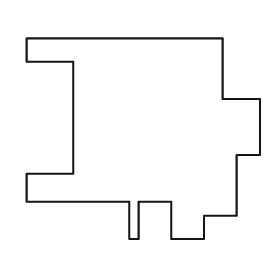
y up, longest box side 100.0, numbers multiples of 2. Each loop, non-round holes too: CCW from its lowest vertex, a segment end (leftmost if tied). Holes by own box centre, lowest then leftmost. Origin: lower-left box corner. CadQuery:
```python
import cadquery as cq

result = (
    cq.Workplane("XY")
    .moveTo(44.0, 0.0)
    .lineTo(48.0, 0.0)
    .lineTo(48.0, 16.0)
    .lineTo(62.0, 16.0)
    .lineTo(62.0, 0.0)
    .lineTo(76.0, 0.0)
    .lineTo(76.0, 10.0)
    .lineTo(90.0, 10.0)
    .lineTo(90.0, 36.0)
    .lineTo(100.0, 36.0)
    .lineTo(100.0, 60.0)
    .lineTo(84.0, 60.0)
    .lineTo(84.0, 86.0)
    .lineTo(0.0, 86.0)
    .lineTo(0.0, 76.0)
    .lineTo(20.0, 76.0)
    .lineTo(20.0, 28.0)
    .lineTo(0.0, 28.0)
    .lineTo(0.0, 16.0)
    .lineTo(44.0, 16.0)
    .close()
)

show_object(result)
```